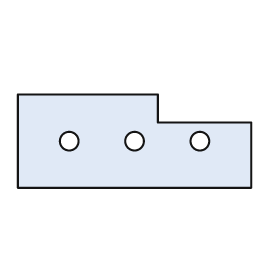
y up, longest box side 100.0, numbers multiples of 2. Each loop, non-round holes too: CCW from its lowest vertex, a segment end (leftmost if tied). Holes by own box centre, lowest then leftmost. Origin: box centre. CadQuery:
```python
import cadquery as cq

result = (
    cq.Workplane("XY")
    .moveTo(-50.0, -20.0)
    .lineTo(50.0, -20.0)
    .lineTo(50.0, 8.0)
    .lineTo(10.0, 8.0)
    .lineTo(10.0, 20.0)
    .lineTo(-50.0, 20.0)
    .close()
    .moveTo(-28.0, 0.0)
    .circle(4.0)
    .moveTo(0.0, 0.0)
    .circle(4.0)
    .moveTo(28.0, 0.0)
    .circle(4.0)
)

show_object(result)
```